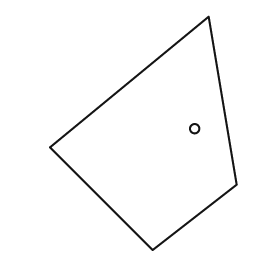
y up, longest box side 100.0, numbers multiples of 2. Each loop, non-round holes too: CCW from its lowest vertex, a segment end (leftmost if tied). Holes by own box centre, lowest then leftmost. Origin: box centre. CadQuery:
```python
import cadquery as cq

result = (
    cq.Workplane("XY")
    .moveTo(4.0, -50.0)
    .lineTo(40.0, -22.0)
    .lineTo(28.0, 50.0)
    .lineTo(-40.0, -6.0)
    .close()
    .moveTo(22.0, 2.0)
    .circle(2.0)
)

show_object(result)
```